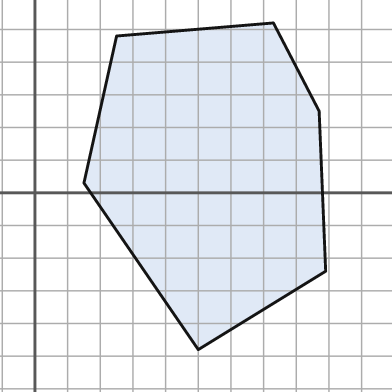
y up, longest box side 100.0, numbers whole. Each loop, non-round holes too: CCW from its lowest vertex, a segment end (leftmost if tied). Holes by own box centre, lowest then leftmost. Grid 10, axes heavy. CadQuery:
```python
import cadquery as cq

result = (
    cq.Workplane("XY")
    .moveTo(50.0, -48.0)
    .lineTo(89.0, -24.0)
    .lineTo(87.0, 25.0)
    .lineTo(73.0, 52.0)
    .lineTo(25.0, 48.0)
    .lineTo(15.0, 3.0)
    .close()
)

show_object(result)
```